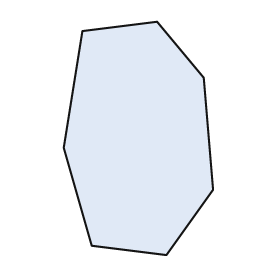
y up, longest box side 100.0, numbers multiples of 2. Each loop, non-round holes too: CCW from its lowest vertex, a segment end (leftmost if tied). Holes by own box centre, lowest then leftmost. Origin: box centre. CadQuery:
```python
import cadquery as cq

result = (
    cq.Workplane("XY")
    .moveTo(12.0, -50.0)
    .lineTo(32.0, -22.0)
    .lineTo(28.0, 26.0)
    .lineTo(8.0, 50.0)
    .lineTo(-24.0, 46.0)
    .lineTo(-32.0, -4.0)
    .lineTo(-20.0, -46.0)
    .close()
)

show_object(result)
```